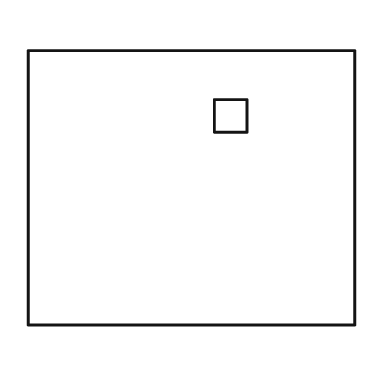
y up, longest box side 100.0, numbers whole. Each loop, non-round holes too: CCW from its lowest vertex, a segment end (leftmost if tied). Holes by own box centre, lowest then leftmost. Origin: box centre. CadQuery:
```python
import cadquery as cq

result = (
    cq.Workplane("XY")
    .moveTo(-50.0, -42.0)
    .lineTo(50.0, -42.0)
    .lineTo(50.0, 42.0)
    .lineTo(-50.0, 42.0)
    .close()
    .moveTo(7.0, 17.0)
    .lineTo(17.0, 17.0)
    .lineTo(17.0, 27.0)
    .lineTo(7.0, 27.0)
    .close()
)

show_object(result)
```